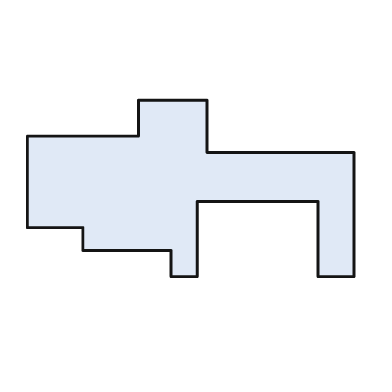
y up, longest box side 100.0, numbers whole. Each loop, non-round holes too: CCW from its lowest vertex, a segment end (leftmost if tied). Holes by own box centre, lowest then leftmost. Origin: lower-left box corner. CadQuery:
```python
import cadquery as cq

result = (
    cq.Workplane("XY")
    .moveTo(44.0, 0.0)
    .lineTo(52.0, 0.0)
    .lineTo(52.0, 23.0)
    .lineTo(89.0, 23.0)
    .lineTo(89.0, 0.0)
    .lineTo(100.0, 0.0)
    .lineTo(100.0, 38.0)
    .lineTo(55.0, 38.0)
    .lineTo(55.0, 54.0)
    .lineTo(34.0, 54.0)
    .lineTo(34.0, 43.0)
    .lineTo(0.0, 43.0)
    .lineTo(0.0, 15.0)
    .lineTo(17.0, 15.0)
    .lineTo(17.0, 8.0)
    .lineTo(44.0, 8.0)
    .close()
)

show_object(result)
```